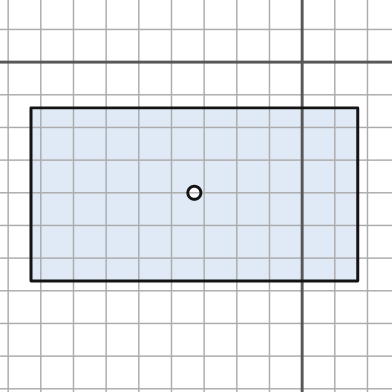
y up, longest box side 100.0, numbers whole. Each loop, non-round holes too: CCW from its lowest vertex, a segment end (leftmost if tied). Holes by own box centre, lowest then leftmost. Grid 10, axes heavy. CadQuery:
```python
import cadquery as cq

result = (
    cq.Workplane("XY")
    .moveTo(-83.0, -67.0)
    .lineTo(17.0, -67.0)
    .lineTo(17.0, -14.0)
    .lineTo(-83.0, -14.0)
    .close()
    .moveTo(-33.0, -40.0)
    .circle(2.0)
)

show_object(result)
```